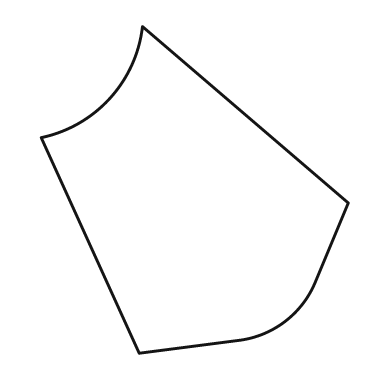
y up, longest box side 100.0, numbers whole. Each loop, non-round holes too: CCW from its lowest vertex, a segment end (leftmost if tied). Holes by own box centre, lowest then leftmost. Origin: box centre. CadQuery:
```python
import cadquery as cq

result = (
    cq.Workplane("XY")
    .moveTo(-17.0, -50.0)
    .lineTo(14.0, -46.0)
    .threePointArc((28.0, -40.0), (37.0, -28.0))
    .lineTo(47.0, -4.0)
    .lineTo(-16.0, 50.0)
    .threePointArc((-26.0, 28.0), (-47.0, 16.0))
    .close()
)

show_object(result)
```